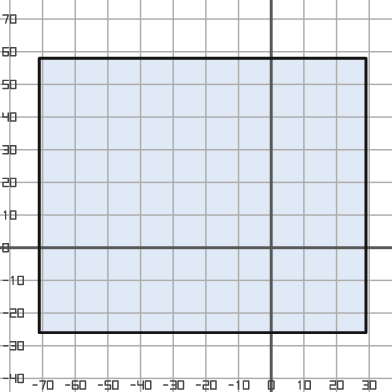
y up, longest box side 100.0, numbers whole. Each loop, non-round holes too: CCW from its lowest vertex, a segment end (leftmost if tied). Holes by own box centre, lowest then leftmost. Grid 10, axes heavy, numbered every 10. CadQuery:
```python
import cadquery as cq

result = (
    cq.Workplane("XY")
    .moveTo(-71.0, -26.0)
    .lineTo(29.0, -26.0)
    .lineTo(29.0, 58.0)
    .lineTo(-71.0, 58.0)
    .close()
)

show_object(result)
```